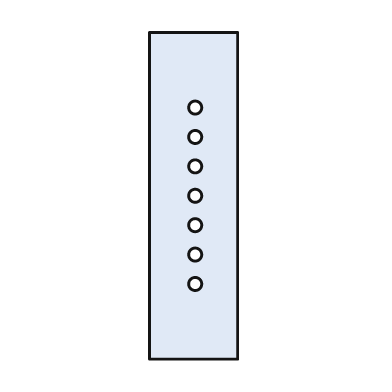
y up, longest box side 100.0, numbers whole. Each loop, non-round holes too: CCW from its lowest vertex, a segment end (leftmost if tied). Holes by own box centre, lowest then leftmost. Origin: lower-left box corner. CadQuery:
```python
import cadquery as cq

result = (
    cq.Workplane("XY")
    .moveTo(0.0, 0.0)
    .lineTo(27.0, 0.0)
    .lineTo(27.0, 100.0)
    .lineTo(0.0, 100.0)
    .close()
    .moveTo(14.0, 23.0)
    .circle(2.0)
    .moveTo(14.0, 32.0)
    .circle(2.0)
    .moveTo(14.0, 41.0)
    .circle(2.0)
    .moveTo(14.0, 50.0)
    .circle(2.0)
    .moveTo(14.0, 59.0)
    .circle(2.0)
    .moveTo(14.0, 68.0)
    .circle(2.0)
    .moveTo(14.0, 77.0)
    .circle(2.0)
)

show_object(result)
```